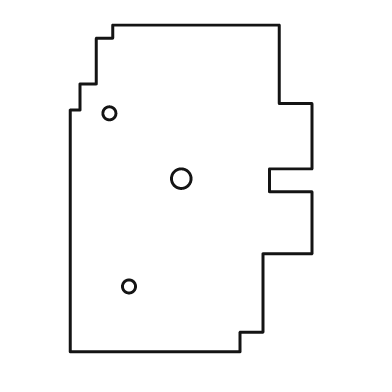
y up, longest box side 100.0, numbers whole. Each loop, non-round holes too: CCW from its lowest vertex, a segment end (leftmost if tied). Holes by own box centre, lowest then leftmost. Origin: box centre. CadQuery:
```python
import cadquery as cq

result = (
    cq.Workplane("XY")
    .moveTo(-37.0, -50.0)
    .lineTo(15.0, -50.0)
    .lineTo(15.0, -44.0)
    .lineTo(22.0, -44.0)
    .lineTo(22.0, -20.0)
    .lineTo(37.0, -20.0)
    .lineTo(37.0, -1.0)
    .lineTo(24.0, -1.0)
    .lineTo(24.0, 6.0)
    .lineTo(37.0, 6.0)
    .lineTo(37.0, 26.0)
    .lineTo(27.0, 26.0)
    .lineTo(27.0, 50.0)
    .lineTo(-24.0, 50.0)
    .lineTo(-24.0, 46.0)
    .lineTo(-29.0, 46.0)
    .lineTo(-29.0, 32.0)
    .lineTo(-34.0, 32.0)
    .lineTo(-34.0, 24.0)
    .lineTo(-37.0, 24.0)
    .close()
    .moveTo(-19.0, -30.0)
    .circle(2.0)
    .moveTo(-3.0, 3.0)
    .circle(3.0)
    .moveTo(-25.0, 23.0)
    .circle(2.0)
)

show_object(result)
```